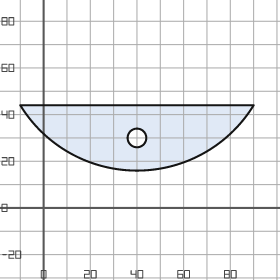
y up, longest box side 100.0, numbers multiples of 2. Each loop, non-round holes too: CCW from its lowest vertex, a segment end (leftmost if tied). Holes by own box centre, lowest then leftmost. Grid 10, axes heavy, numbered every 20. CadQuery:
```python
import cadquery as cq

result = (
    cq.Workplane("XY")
    .moveTo(-10.0, 44.0)
    .threePointArc((40.0, 16.0), (90.0, 44.0))
    .close()
    .moveTo(40.0, 30.0)
    .circle(4.0)
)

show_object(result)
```